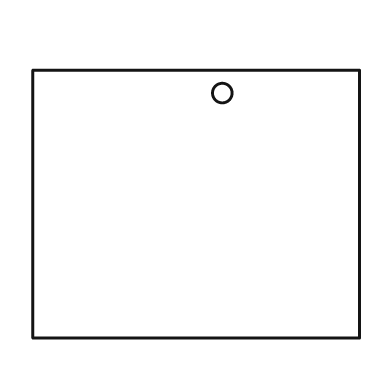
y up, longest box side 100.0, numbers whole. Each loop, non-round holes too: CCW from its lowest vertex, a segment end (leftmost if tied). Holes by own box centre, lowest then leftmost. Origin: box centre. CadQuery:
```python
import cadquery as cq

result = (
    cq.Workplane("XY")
    .moveTo(-50.0, -41.0)
    .lineTo(50.0, -41.0)
    .lineTo(50.0, 41.0)
    .lineTo(-50.0, 41.0)
    .close()
    .moveTo(8.0, 34.0)
    .circle(3.0)
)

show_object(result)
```